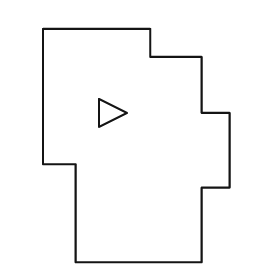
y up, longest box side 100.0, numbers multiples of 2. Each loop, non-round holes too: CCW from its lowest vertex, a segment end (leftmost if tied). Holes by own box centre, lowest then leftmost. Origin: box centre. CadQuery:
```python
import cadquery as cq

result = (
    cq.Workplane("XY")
    .moveTo(-26.0, -50.0)
    .lineTo(28.0, -50.0)
    .lineTo(28.0, -18.0)
    .lineTo(40.0, -18.0)
    .lineTo(40.0, 14.0)
    .lineTo(28.0, 14.0)
    .lineTo(28.0, 38.0)
    .lineTo(6.0, 38.0)
    .lineTo(6.0, 50.0)
    .lineTo(-40.0, 50.0)
    .lineTo(-40.0, -8.0)
    .lineTo(-26.0, -8.0)
    .close()
    .moveTo(-16.0, 8.0)
    .lineTo(-4.0, 14.0)
    .lineTo(-16.0, 20.0)
    .close()
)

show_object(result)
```